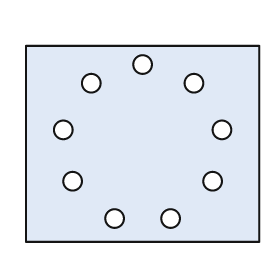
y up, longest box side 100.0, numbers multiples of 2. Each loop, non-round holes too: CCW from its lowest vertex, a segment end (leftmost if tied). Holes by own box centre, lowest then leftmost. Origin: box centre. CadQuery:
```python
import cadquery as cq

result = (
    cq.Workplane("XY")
    .moveTo(-50.0, -42.0)
    .lineTo(50.0, -42.0)
    .lineTo(50.0, 42.0)
    .lineTo(-50.0, 42.0)
    .close()
    .moveTo(-12.0, -32.0)
    .circle(4.0)
    .moveTo(12.0, -32.0)
    .circle(4.0)
    .moveTo(-30.0, -16.0)
    .circle(4.0)
    .moveTo(30.0, -16.0)
    .circle(4.0)
    .moveTo(-34.0, 6.0)
    .circle(4.0)
    .moveTo(34.0, 6.0)
    .circle(4.0)
    .moveTo(-22.0, 26.0)
    .circle(4.0)
    .moveTo(22.0, 26.0)
    .circle(4.0)
    .moveTo(0.0, 34.0)
    .circle(4.0)
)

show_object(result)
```